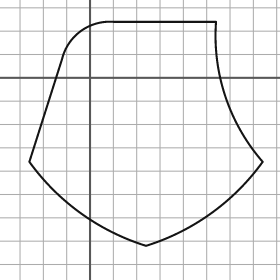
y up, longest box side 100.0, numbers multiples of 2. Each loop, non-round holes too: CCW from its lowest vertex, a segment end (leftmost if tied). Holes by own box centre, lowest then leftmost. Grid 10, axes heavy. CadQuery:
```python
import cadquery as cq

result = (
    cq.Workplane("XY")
    .moveTo(24.0, -72.0)
    .threePointArc((52.0, -58.0), (74.0, -36.0))
    .threePointArc((58.0, -8.0), (54.0, 24.0))
    .lineTo(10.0, 24.0)
    .threePointArc((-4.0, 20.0), (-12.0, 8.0))
    .lineTo(-26.0, -36.0)
    .threePointArc((-4.0, -58.0), (24.0, -72.0))
    .close()
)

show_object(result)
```